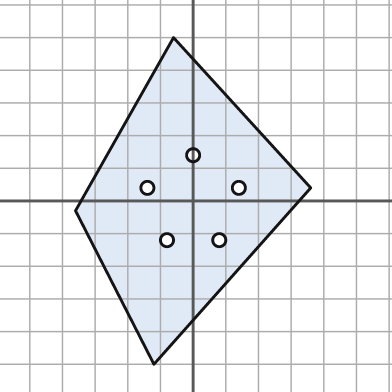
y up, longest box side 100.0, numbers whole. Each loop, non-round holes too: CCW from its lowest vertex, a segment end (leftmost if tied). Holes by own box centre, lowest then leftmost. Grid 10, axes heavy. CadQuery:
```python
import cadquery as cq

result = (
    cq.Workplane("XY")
    .moveTo(-12.0, -50.0)
    .lineTo(36.0, 4.0)
    .lineTo(-6.0, 50.0)
    .lineTo(-36.0, -3.0)
    .close()
    .moveTo(-8.0, -12.0)
    .circle(2.0)
    .moveTo(8.0, -12.0)
    .circle(2.0)
    .moveTo(-14.0, 4.0)
    .circle(2.0)
    .moveTo(14.0, 4.0)
    .circle(2.0)
    .moveTo(0.0, 14.0)
    .circle(2.0)
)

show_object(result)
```